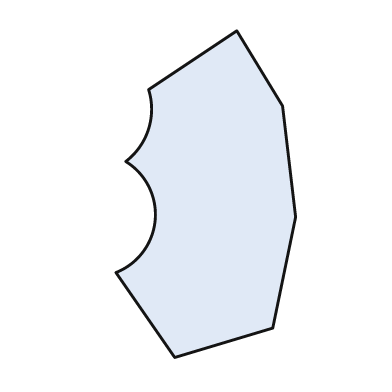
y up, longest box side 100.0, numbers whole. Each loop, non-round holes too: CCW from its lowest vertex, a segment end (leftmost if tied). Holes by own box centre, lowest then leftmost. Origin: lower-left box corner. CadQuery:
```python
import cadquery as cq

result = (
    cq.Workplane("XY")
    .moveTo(18.0, 0.0)
    .lineTo(48.0, 9.0)
    .lineTo(55.0, 43.0)
    .lineTo(51.0, 77.0)
    .lineTo(37.0, 100.0)
    .lineTo(10.0, 82.0)
    .threePointArc((10.0, 70.0), (3.0, 60.0))
    .threePointArc((12.0, 42.0), (0.0, 26.0))
    .close()
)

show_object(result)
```